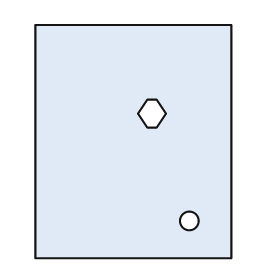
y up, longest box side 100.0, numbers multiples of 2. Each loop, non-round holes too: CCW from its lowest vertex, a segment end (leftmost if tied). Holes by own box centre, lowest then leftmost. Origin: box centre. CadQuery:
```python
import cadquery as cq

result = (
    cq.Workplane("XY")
    .moveTo(-42.0, -50.0)
    .lineTo(42.0, -50.0)
    .lineTo(42.0, 50.0)
    .lineTo(-42.0, 50.0)
    .close()
    .moveTo(24.0, -34.0)
    .circle(4.0)
    .moveTo(6.0, 6.0)
    .lineTo(10.0, 6.0)
    .lineTo(14.0, 12.0)
    .lineTo(10.0, 18.0)
    .lineTo(6.0, 18.0)
    .lineTo(2.0, 12.0)
    .close()
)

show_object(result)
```